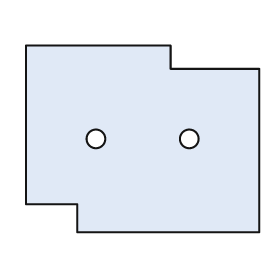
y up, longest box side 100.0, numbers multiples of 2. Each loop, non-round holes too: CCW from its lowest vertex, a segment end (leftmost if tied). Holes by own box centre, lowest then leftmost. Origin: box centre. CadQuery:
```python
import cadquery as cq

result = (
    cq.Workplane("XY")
    .moveTo(-28.0, -40.0)
    .lineTo(50.0, -40.0)
    .lineTo(50.0, 30.0)
    .lineTo(12.0, 30.0)
    .lineTo(12.0, 40.0)
    .lineTo(-50.0, 40.0)
    .lineTo(-50.0, -28.0)
    .lineTo(-28.0, -28.0)
    .close()
    .moveTo(-20.0, 0.0)
    .circle(4.0)
    .moveTo(20.0, 0.0)
    .circle(4.0)
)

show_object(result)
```